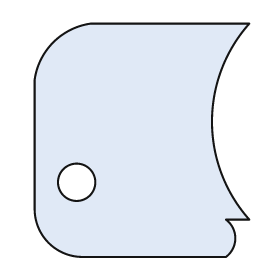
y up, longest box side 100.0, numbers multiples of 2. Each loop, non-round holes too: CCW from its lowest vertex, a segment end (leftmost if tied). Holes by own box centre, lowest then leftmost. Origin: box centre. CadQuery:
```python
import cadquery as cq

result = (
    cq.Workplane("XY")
    .moveTo(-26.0, -50.0)
    .lineTo(36.0, -50.0)
    .threePointArc((40.0, -42.0), (36.0, -34.0))
    .lineTo(46.0, -34.0)
    .threePointArc((30.0, 8.0), (46.0, 50.0))
    .lineTo(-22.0, 50.0)
    .threePointArc((-38.0, 42.0), (-46.0, 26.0))
    .lineTo(-46.0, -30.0)
    .threePointArc((-40.0, -44.0), (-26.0, -50.0))
    .close()
    .moveTo(-28.0, -18.0)
    .circle(8.0)
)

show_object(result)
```